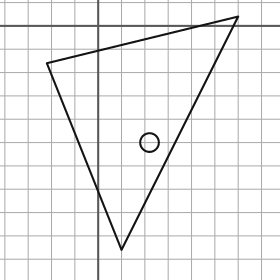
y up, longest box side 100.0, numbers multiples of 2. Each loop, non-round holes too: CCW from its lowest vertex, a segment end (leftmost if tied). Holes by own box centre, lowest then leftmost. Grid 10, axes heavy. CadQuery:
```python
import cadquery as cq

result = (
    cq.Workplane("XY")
    .moveTo(10.0, -96.0)
    .lineTo(60.0, 4.0)
    .lineTo(-22.0, -16.0)
    .close()
    .moveTo(22.0, -50.0)
    .circle(4.0)
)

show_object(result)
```